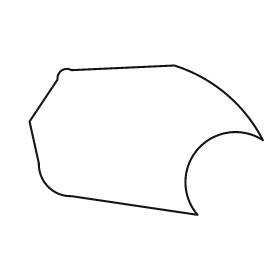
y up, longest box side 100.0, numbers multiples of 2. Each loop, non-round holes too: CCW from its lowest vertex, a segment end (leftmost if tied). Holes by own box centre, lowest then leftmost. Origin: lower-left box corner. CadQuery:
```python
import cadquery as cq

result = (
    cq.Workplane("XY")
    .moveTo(72.0, 0.0)
    .threePointArc((72.0, 28.0), (100.0, 32.0))
    .threePointArc((84.0, 52.0), (62.0, 64.0))
    .lineTo(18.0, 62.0)
    .threePointArc((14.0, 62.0), (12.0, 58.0))
    .lineTo(0.0, 40.0)
    .lineTo(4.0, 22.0)
    .threePointArc((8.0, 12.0), (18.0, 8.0))
    .close()
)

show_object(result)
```